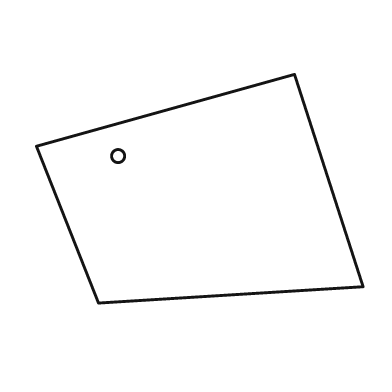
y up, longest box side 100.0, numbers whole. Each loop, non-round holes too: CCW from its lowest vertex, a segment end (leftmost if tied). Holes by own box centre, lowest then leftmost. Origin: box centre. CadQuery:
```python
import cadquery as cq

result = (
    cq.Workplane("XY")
    .moveTo(-31.0, -35.0)
    .lineTo(50.0, -30.0)
    .lineTo(29.0, 35.0)
    .lineTo(-50.0, 13.0)
    .close()
    .moveTo(-25.0, 10.0)
    .circle(2.0)
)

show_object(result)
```